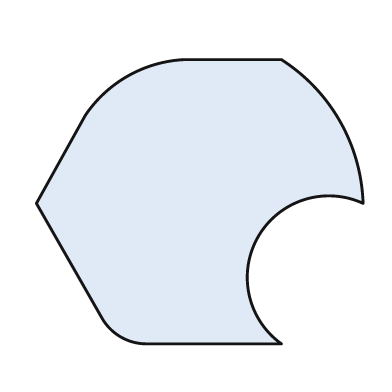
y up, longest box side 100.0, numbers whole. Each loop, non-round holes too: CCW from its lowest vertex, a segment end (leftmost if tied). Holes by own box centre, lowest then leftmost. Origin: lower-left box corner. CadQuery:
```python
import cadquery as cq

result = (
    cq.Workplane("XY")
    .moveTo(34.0, 0.0)
    .lineTo(75.0, 0.0)
    .threePointArc((68.0, 33.0), (100.0, 43.0))
    .threePointArc((93.0, 68.0), (75.0, 87.0))
    .lineTo(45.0, 87.0)
    .threePointArc((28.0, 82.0), (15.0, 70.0))
    .lineTo(0.0, 43.0)
    .lineTo(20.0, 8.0)
    .threePointArc((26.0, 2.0), (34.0, 0.0))
    .close()
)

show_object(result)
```